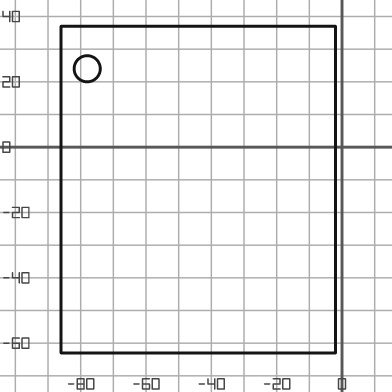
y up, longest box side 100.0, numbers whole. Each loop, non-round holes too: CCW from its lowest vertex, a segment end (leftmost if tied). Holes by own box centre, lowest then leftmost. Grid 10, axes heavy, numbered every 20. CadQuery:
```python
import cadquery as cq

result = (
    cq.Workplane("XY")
    .moveTo(-86.0, -63.0)
    .lineTo(-2.0, -63.0)
    .lineTo(-2.0, 37.0)
    .lineTo(-86.0, 37.0)
    .close()
    .moveTo(-78.0, 24.0)
    .circle(4.0)
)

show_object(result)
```